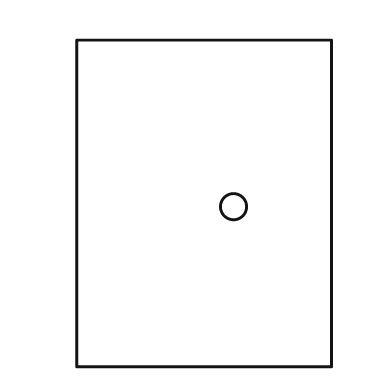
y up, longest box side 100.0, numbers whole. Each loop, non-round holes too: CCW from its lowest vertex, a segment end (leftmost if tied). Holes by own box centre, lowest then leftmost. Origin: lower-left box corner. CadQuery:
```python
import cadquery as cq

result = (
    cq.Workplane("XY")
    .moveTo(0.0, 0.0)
    .lineTo(78.0, 0.0)
    .lineTo(78.0, 100.0)
    .lineTo(0.0, 100.0)
    .close()
    .moveTo(48.0, 49.0)
    .circle(4.0)
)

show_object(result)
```